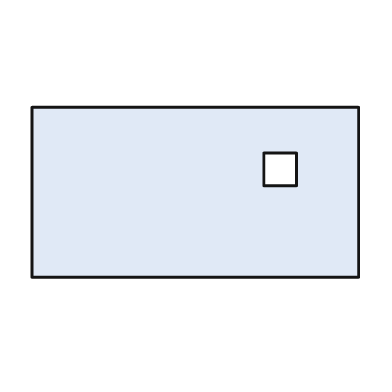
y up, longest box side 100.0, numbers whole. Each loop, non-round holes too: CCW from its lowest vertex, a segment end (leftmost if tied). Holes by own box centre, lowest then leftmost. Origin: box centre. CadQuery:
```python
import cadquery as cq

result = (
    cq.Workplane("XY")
    .moveTo(-50.0, -26.0)
    .lineTo(50.0, -26.0)
    .lineTo(50.0, 26.0)
    .lineTo(-50.0, 26.0)
    .close()
    .moveTo(21.0, 2.0)
    .lineTo(31.0, 2.0)
    .lineTo(31.0, 12.0)
    .lineTo(21.0, 12.0)
    .close()
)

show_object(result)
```